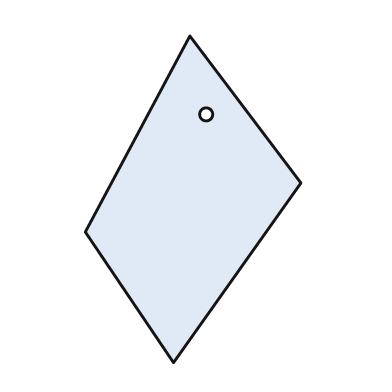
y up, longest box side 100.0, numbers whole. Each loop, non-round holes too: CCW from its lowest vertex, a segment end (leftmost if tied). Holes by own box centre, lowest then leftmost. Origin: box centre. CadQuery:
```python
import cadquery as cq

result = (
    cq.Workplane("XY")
    .moveTo(-6.0, -50.0)
    .lineTo(33.0, 5.0)
    .lineTo(-1.0, 50.0)
    .lineTo(-33.0, -10.0)
    .close()
    .moveTo(4.0, 26.0)
    .circle(2.0)
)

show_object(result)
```